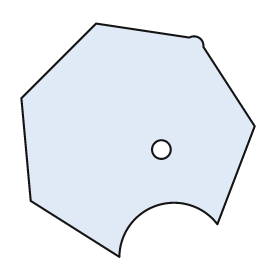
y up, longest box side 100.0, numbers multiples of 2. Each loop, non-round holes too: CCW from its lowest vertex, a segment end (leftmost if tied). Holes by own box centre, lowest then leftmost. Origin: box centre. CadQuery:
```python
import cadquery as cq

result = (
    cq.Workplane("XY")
    .moveTo(-8.0, -50.0)
    .threePointArc((8.0, -28.0), (34.0, -36.0))
    .lineTo(50.0, 6.0)
    .lineTo(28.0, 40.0)
    .threePointArc((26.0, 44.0), (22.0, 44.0))
    .lineTo(-18.0, 50.0)
    .lineTo(-50.0, 18.0)
    .lineTo(-46.0, -26.0)
    .close()
    .moveTo(10.0, -4.0)
    .circle(4.0)
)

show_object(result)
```